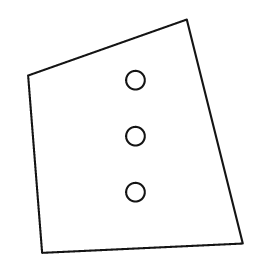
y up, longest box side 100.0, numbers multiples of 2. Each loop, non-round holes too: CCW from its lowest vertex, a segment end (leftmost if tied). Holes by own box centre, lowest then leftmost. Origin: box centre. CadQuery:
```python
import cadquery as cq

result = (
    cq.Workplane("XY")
    .moveTo(-40.0, -50.0)
    .lineTo(46.0, -46.0)
    .lineTo(22.0, 50.0)
    .lineTo(-46.0, 26.0)
    .close()
    .moveTo(0.0, -24.0)
    .circle(4.0)
    .moveTo(0.0, 0.0)
    .circle(4.0)
    .moveTo(0.0, 24.0)
    .circle(4.0)
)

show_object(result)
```